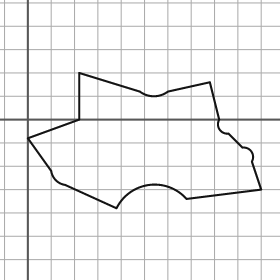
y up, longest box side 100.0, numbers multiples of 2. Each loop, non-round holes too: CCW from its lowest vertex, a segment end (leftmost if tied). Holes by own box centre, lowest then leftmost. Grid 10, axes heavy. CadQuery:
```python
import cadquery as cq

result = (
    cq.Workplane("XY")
    .moveTo(38.0, -38.0)
    .threePointArc((52.0, -28.0), (68.0, -34.0))
    .lineTo(100.0, -30.0)
    .lineTo(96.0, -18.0)
    .threePointArc((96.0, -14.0), (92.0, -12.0))
    .lineTo(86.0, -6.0)
    .threePointArc((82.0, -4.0), (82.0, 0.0))
    .lineTo(78.0, 16.0)
    .lineTo(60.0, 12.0)
    .threePointArc((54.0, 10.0), (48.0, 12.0))
    .lineTo(22.0, 20.0)
    .lineTo(22.0, 0.0)
    .lineTo(0.0, -8.0)
    .lineTo(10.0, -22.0)
    .threePointArc((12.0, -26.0), (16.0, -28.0))
    .close()
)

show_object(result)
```